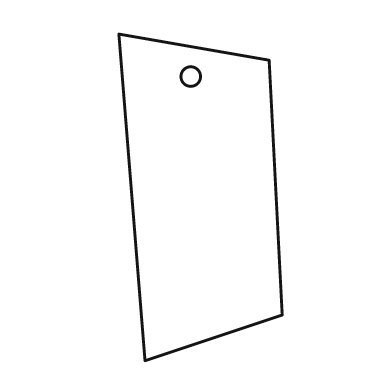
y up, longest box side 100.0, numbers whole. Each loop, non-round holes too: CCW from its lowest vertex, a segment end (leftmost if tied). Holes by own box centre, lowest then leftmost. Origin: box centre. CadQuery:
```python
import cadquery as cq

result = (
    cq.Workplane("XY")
    .moveTo(-17.0, -50.0)
    .lineTo(25.0, -36.0)
    .lineTo(21.0, 42.0)
    .lineTo(-25.0, 50.0)
    .close()
    .moveTo(-3.0, 37.0)
    .circle(3.0)
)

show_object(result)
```